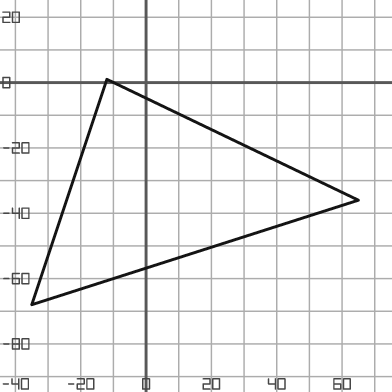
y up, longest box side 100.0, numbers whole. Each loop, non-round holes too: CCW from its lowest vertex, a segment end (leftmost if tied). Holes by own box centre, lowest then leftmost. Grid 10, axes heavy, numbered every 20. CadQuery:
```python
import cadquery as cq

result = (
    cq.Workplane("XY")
    .moveTo(-35.0, -68.0)
    .lineTo(65.0, -36.0)
    .lineTo(-12.0, 1.0)
    .close()
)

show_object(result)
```